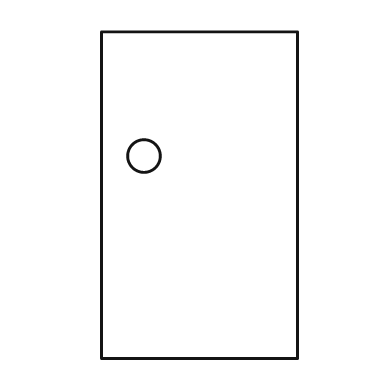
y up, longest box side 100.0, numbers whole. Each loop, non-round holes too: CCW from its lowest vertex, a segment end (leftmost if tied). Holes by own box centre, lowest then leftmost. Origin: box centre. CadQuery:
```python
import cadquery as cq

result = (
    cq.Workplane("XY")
    .moveTo(-30.0, -50.0)
    .lineTo(30.0, -50.0)
    .lineTo(30.0, 50.0)
    .lineTo(-30.0, 50.0)
    .close()
    .moveTo(-17.0, 12.0)
    .circle(5.0)
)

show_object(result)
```